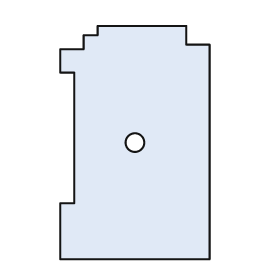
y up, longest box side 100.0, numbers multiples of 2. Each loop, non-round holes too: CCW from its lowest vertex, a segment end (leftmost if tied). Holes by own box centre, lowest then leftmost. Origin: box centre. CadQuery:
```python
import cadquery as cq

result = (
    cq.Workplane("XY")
    .moveTo(-32.0, -50.0)
    .lineTo(32.0, -50.0)
    .lineTo(32.0, 42.0)
    .lineTo(22.0, 42.0)
    .lineTo(22.0, 50.0)
    .lineTo(-16.0, 50.0)
    .lineTo(-16.0, 46.0)
    .lineTo(-22.0, 46.0)
    .lineTo(-22.0, 40.0)
    .lineTo(-32.0, 40.0)
    .lineTo(-32.0, 30.0)
    .lineTo(-26.0, 30.0)
    .lineTo(-26.0, -26.0)
    .lineTo(-32.0, -26.0)
    .close()
    .moveTo(0.0, 0.0)
    .circle(4.0)
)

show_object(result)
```